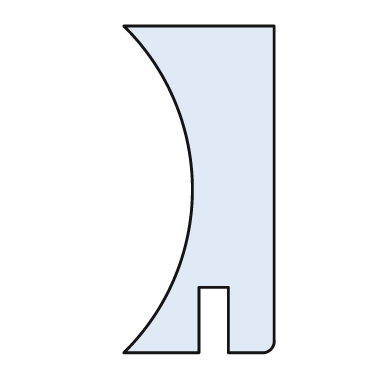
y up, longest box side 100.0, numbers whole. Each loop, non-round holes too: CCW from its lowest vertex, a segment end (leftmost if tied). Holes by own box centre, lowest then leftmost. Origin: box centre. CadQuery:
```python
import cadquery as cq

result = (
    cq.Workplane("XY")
    .moveTo(-23.0, -50.0)
    .lineTo(0.0, -50.0)
    .lineTo(0.0, -30.0)
    .lineTo(9.0, -30.0)
    .lineTo(9.0, -50.0)
    .lineTo(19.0, -50.0)
    .threePointArc((22.0, -49.0), (23.0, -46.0))
    .lineTo(23.0, 50.0)
    .lineTo(-23.0, 50.0)
    .threePointArc((-2.0, 0.0), (-23.0, -50.0))
    .close()
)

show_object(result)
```